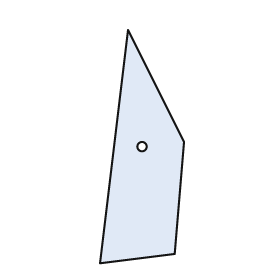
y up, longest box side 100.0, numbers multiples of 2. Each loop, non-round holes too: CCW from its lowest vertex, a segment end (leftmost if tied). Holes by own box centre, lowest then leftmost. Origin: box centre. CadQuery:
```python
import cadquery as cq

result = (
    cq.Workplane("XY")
    .moveTo(-18.0, -50.0)
    .lineTo(14.0, -46.0)
    .lineTo(18.0, 2.0)
    .lineTo(-6.0, 50.0)
    .close()
    .moveTo(0.0, 0.0)
    .circle(2.0)
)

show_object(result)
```